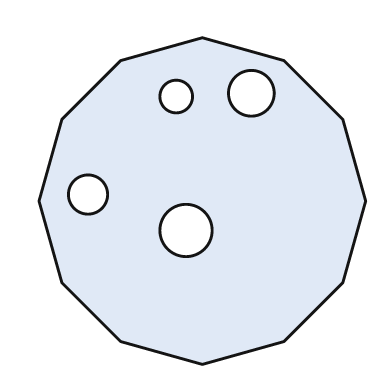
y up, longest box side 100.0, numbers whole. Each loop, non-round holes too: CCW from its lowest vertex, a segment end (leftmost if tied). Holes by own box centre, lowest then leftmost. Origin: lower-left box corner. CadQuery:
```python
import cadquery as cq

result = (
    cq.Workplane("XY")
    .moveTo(50.0, 0.0)
    .lineTo(75.0, 7.0)
    .lineTo(93.0, 25.0)
    .lineTo(100.0, 50.0)
    .lineTo(93.0, 75.0)
    .lineTo(75.0, 93.0)
    .lineTo(50.0, 100.0)
    .lineTo(25.0, 93.0)
    .lineTo(7.0, 75.0)
    .lineTo(0.0, 50.0)
    .lineTo(7.0, 25.0)
    .lineTo(25.0, 7.0)
    .close()
    .moveTo(45.0, 41.0)
    .circle(8.0)
    .moveTo(15.0, 52.0)
    .circle(6.0)
    .moveTo(42.0, 82.0)
    .circle(5.0)
    .moveTo(65.0, 83.0)
    .circle(7.0)
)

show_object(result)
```